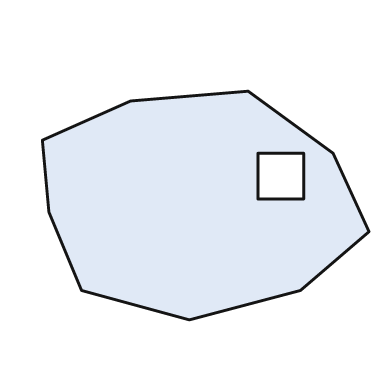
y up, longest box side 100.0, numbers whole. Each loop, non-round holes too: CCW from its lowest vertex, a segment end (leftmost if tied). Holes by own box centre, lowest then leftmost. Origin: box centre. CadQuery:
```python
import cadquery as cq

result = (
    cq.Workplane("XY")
    .moveTo(-5.0, -35.0)
    .lineTo(29.0, -26.0)
    .lineTo(50.0, -8.0)
    .lineTo(39.0, 16.0)
    .lineTo(13.0, 35.0)
    .lineTo(-23.0, 32.0)
    .lineTo(-50.0, 20.0)
    .lineTo(-48.0, -2.0)
    .lineTo(-38.0, -26.0)
    .close()
    .moveTo(16.0, 2.0)
    .lineTo(30.0, 2.0)
    .lineTo(30.0, 16.0)
    .lineTo(16.0, 16.0)
    .close()
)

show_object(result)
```